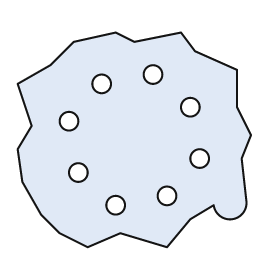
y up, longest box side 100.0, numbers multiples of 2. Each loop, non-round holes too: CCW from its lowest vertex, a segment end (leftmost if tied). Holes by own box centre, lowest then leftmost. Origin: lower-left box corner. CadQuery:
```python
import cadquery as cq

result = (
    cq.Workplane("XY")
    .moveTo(30.0, 0.0)
    .lineTo(44.0, 6.0)
    .lineTo(64.0, 0.0)
    .lineTo(74.0, 12.0)
    .lineTo(84.0, 18.0)
    .threePointArc((92.0, 12.0), (98.0, 20.0))
    .lineTo(96.0, 38.0)
    .lineTo(100.0, 48.0)
    .lineTo(94.0, 60.0)
    .lineTo(94.0, 76.0)
    .lineTo(76.0, 84.0)
    .lineTo(70.0, 92.0)
    .lineTo(50.0, 88.0)
    .lineTo(42.0, 92.0)
    .lineTo(24.0, 88.0)
    .lineTo(14.0, 78.0)
    .lineTo(0.0, 70.0)
    .lineTo(6.0, 52.0)
    .lineTo(0.0, 42.0)
    .lineTo(2.0, 28.0)
    .lineTo(10.0, 14.0)
    .lineTo(18.0, 6.0)
    .close()
    .moveTo(42.0, 18.0)
    .circle(4.0)
    .moveTo(64.0, 22.0)
    .circle(4.0)
    .moveTo(26.0, 32.0)
    .circle(4.0)
    .moveTo(78.0, 38.0)
    .circle(4.0)
    .moveTo(22.0, 54.0)
    .circle(4.0)
    .moveTo(74.0, 60.0)
    .circle(4.0)
    .moveTo(36.0, 70.0)
    .circle(4.0)
    .moveTo(58.0, 74.0)
    .circle(4.0)
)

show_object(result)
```